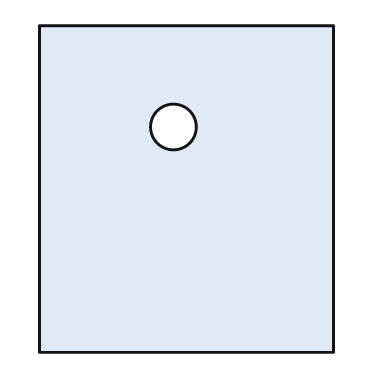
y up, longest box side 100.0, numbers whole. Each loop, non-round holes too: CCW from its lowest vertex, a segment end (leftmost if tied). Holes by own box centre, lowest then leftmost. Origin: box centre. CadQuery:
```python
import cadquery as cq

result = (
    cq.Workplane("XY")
    .moveTo(-45.0, -50.0)
    .lineTo(45.0, -50.0)
    .lineTo(45.0, 50.0)
    .lineTo(-45.0, 50.0)
    .close()
    .moveTo(-4.0, 19.0)
    .circle(7.0)
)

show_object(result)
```